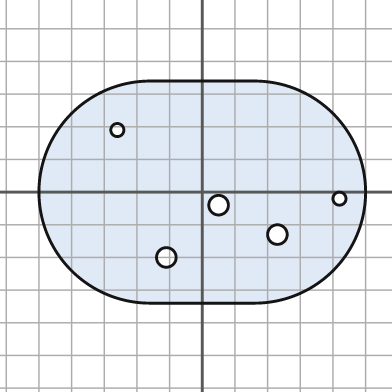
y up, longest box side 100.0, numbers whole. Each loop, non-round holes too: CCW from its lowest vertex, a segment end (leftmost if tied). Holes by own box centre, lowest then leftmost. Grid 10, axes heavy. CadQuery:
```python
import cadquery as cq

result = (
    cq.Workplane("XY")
    .moveTo(-16.0, -34.0)
    .lineTo(16.0, -34.0)
    .threePointArc((50.0, 0.0), (16.0, 34.0))
    .lineTo(-16.0, 34.0)
    .threePointArc((-50.0, 0.0), (-16.0, -34.0))
    .close()
    .moveTo(-11.0, -20.0)
    .circle(3.0)
    .moveTo(23.0, -13.0)
    .circle(3.0)
    .moveTo(5.0, -4.0)
    .circle(3.0)
    .moveTo(42.0, -2.0)
    .circle(2.0)
    .moveTo(-26.0, 19.0)
    .circle(2.0)
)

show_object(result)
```